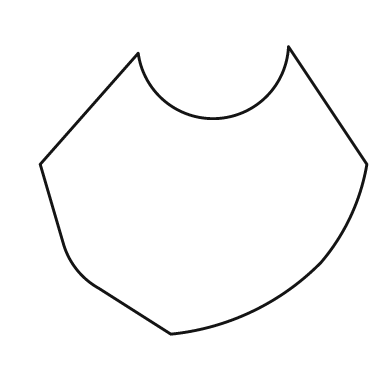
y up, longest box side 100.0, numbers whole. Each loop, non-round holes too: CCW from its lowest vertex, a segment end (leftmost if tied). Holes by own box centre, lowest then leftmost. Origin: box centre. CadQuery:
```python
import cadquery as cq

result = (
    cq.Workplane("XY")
    .moveTo(-10.0, -44.0)
    .threePointArc((15.0, -37.0), (36.0, -22.0))
    .threePointArc((45.0, -8.0), (50.0, 8.0))
    .lineTo(26.0, 44.0)
    .threePointArc((4.0, 22.0), (-20.0, 42.0))
    .lineTo(-50.0, 8.0)
    .lineTo(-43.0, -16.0)
    .threePointArc((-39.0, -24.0), (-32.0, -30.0))
    .close()
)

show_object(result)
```